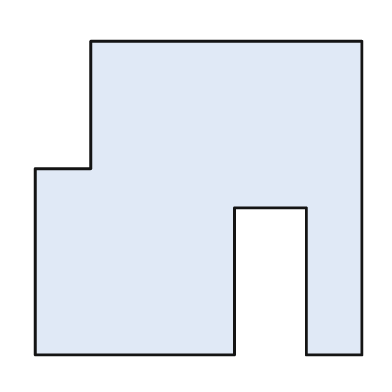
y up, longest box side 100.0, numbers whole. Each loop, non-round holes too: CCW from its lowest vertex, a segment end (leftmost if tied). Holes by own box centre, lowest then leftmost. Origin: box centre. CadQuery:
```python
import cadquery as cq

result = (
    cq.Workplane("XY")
    .moveTo(-50.0, -48.0)
    .lineTo(11.0, -48.0)
    .lineTo(11.0, -3.0)
    .lineTo(33.0, -3.0)
    .lineTo(33.0, -48.0)
    .lineTo(50.0, -48.0)
    .lineTo(50.0, 48.0)
    .lineTo(-33.0, 48.0)
    .lineTo(-33.0, 9.0)
    .lineTo(-50.0, 9.0)
    .close()
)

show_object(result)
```